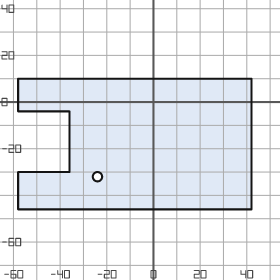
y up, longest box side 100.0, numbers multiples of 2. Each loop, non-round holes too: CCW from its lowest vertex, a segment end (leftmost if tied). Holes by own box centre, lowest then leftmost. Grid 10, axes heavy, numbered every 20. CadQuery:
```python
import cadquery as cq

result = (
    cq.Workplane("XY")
    .moveTo(-58.0, -46.0)
    .lineTo(42.0, -46.0)
    .lineTo(42.0, 10.0)
    .lineTo(-58.0, 10.0)
    .lineTo(-58.0, -4.0)
    .lineTo(-36.0, -4.0)
    .lineTo(-36.0, -30.0)
    .lineTo(-58.0, -30.0)
    .close()
    .moveTo(-24.0, -32.0)
    .circle(2.0)
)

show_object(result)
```